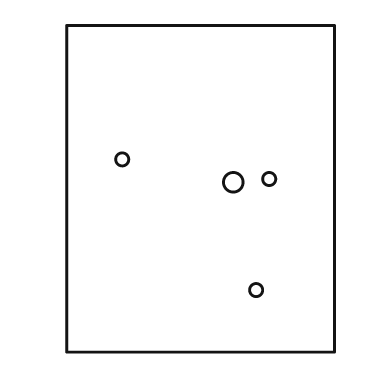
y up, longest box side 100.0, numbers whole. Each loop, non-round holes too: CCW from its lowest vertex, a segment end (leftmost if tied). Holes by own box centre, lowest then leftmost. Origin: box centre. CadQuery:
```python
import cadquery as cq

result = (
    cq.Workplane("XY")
    .moveTo(-41.0, -50.0)
    .lineTo(41.0, -50.0)
    .lineTo(41.0, 50.0)
    .lineTo(-41.0, 50.0)
    .close()
    .moveTo(17.0, -31.0)
    .circle(2.0)
    .moveTo(10.0, 2.0)
    .circle(3.0)
    .moveTo(21.0, 3.0)
    .circle(2.0)
    .moveTo(-24.0, 9.0)
    .circle(2.0)
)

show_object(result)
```